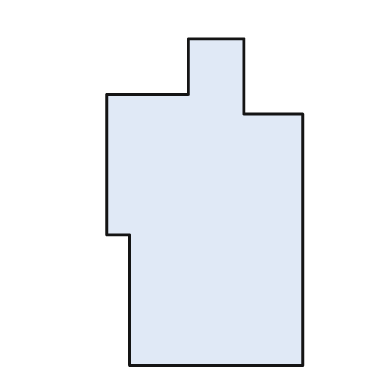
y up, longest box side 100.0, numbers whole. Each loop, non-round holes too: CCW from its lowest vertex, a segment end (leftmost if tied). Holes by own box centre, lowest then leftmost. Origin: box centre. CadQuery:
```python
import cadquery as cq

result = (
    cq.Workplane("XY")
    .moveTo(-23.0, -50.0)
    .lineTo(30.0, -50.0)
    .lineTo(30.0, 27.0)
    .lineTo(12.0, 27.0)
    .lineTo(12.0, 50.0)
    .lineTo(-5.0, 50.0)
    .lineTo(-5.0, 33.0)
    .lineTo(-30.0, 33.0)
    .lineTo(-30.0, -10.0)
    .lineTo(-23.0, -10.0)
    .close()
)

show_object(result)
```